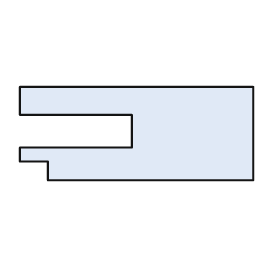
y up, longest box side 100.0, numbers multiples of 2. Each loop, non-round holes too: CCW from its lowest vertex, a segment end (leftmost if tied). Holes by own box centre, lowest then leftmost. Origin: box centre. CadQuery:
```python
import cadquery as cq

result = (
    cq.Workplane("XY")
    .moveTo(-38.0, -20.0)
    .lineTo(50.0, -20.0)
    .lineTo(50.0, 20.0)
    .lineTo(-50.0, 20.0)
    .lineTo(-50.0, 8.0)
    .lineTo(-2.0, 8.0)
    .lineTo(-2.0, -6.0)
    .lineTo(-50.0, -6.0)
    .lineTo(-50.0, -12.0)
    .lineTo(-38.0, -12.0)
    .close()
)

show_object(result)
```